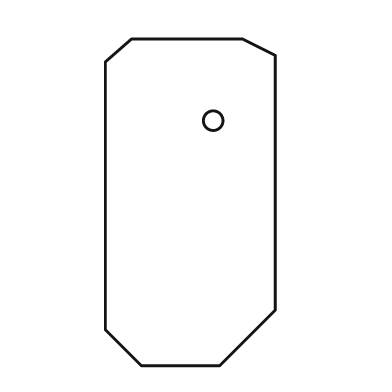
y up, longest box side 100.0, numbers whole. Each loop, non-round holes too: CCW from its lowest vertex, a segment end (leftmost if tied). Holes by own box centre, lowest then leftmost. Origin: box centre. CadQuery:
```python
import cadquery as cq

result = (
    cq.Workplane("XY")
    .moveTo(-15.0, -50.0)
    .lineTo(9.0, -50.0)
    .lineTo(26.0, -33.0)
    .lineTo(26.0, 45.0)
    .lineTo(16.0, 50.0)
    .lineTo(-18.0, 50.0)
    .lineTo(-26.0, 43.0)
    .lineTo(-26.0, -39.0)
    .close()
    .moveTo(7.0, 25.0)
    .circle(3.0)
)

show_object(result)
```